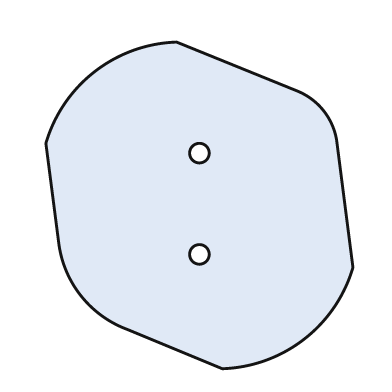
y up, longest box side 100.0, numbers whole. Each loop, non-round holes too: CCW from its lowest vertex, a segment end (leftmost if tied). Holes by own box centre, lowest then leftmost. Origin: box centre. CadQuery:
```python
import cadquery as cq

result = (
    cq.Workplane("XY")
    .moveTo(7.0, -50.0)
    .threePointArc((32.0, -41.0), (47.0, -19.0))
    .lineTo(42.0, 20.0)
    .threePointArc((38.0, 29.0), (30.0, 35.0))
    .lineTo(-7.0, 50.0)
    .threePointArc((-32.0, 41.0), (-47.0, 19.0))
    .lineTo(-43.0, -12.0)
    .threePointArc((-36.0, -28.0), (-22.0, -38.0))
    .close()
    .moveTo(0.0, -15.0)
    .circle(3.0)
    .moveTo(0.0, 16.0)
    .circle(3.0)
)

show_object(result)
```